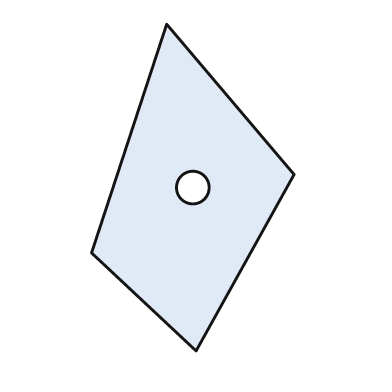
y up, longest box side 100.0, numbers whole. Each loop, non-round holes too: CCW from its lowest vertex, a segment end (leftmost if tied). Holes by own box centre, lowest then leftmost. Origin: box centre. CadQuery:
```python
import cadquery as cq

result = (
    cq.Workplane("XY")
    .moveTo(1.0, -50.0)
    .lineTo(31.0, 4.0)
    .lineTo(-8.0, 50.0)
    .lineTo(-31.0, -20.0)
    .close()
    .moveTo(0.0, 0.0)
    .circle(5.0)
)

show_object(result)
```